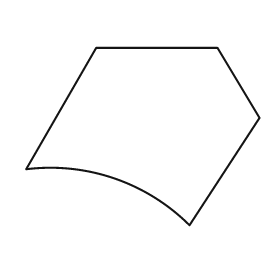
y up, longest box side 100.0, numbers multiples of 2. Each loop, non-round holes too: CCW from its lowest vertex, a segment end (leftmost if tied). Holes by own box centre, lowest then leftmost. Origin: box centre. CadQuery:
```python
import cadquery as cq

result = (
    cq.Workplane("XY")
    .moveTo(20.0, -38.0)
    .lineTo(50.0, 8.0)
    .lineTo(32.0, 38.0)
    .lineTo(-20.0, 38.0)
    .lineTo(-50.0, -14.0)
    .threePointArc((-12.0, -18.0), (20.0, -38.0))
    .close()
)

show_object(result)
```